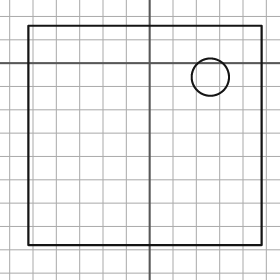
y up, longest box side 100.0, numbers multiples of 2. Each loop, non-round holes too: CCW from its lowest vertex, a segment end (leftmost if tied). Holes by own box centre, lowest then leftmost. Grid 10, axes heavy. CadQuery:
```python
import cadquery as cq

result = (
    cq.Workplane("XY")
    .moveTo(-52.0, -78.0)
    .lineTo(48.0, -78.0)
    .lineTo(48.0, 16.0)
    .lineTo(-52.0, 16.0)
    .close()
    .moveTo(26.0, -6.0)
    .circle(8.0)
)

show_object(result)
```